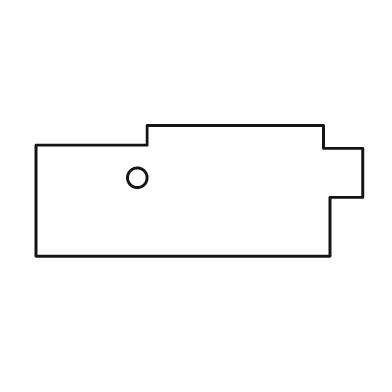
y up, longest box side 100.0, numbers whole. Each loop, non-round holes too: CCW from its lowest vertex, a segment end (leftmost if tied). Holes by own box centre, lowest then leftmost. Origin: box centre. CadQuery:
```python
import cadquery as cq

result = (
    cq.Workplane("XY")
    .moveTo(-50.0, -20.0)
    .lineTo(40.0, -20.0)
    .lineTo(40.0, -2.0)
    .lineTo(50.0, -2.0)
    .lineTo(50.0, 13.0)
    .lineTo(38.0, 13.0)
    .lineTo(38.0, 20.0)
    .lineTo(-16.0, 20.0)
    .lineTo(-16.0, 14.0)
    .lineTo(-50.0, 14.0)
    .close()
    .moveTo(-19.0, 4.0)
    .circle(3.0)
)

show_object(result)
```